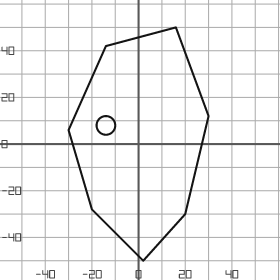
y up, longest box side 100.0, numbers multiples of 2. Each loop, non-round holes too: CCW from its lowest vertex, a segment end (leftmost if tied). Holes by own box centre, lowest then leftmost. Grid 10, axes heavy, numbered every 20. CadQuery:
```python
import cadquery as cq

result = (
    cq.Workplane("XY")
    .moveTo(2.0, -50.0)
    .lineTo(20.0, -30.0)
    .lineTo(30.0, 12.0)
    .lineTo(16.0, 50.0)
    .lineTo(-14.0, 42.0)
    .lineTo(-30.0, 6.0)
    .lineTo(-20.0, -28.0)
    .close()
    .moveTo(-14.0, 8.0)
    .circle(4.0)
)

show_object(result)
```